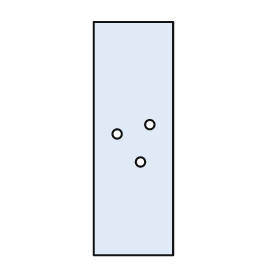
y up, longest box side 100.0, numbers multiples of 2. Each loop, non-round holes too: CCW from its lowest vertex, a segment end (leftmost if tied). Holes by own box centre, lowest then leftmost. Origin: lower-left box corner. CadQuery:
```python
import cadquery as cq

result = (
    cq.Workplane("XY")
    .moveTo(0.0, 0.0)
    .lineTo(34.0, 0.0)
    .lineTo(34.0, 100.0)
    .lineTo(0.0, 100.0)
    .close()
    .moveTo(20.0, 40.0)
    .circle(2.0)
    .moveTo(10.0, 52.0)
    .circle(2.0)
    .moveTo(24.0, 56.0)
    .circle(2.0)
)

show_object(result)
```